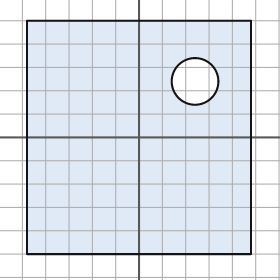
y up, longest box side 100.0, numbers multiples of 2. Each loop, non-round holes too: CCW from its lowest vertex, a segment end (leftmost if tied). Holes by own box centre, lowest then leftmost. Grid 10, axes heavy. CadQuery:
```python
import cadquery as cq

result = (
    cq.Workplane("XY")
    .moveTo(-48.0, -50.0)
    .lineTo(48.0, -50.0)
    .lineTo(48.0, 50.0)
    .lineTo(-48.0, 50.0)
    .close()
    .moveTo(24.0, 24.0)
    .circle(10.0)
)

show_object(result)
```